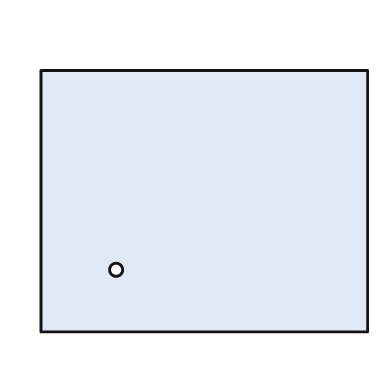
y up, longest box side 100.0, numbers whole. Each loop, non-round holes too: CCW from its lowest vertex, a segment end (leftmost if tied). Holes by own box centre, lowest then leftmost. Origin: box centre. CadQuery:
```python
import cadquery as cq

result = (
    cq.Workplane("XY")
    .moveTo(-50.0, -40.0)
    .lineTo(50.0, -40.0)
    .lineTo(50.0, 40.0)
    .lineTo(-50.0, 40.0)
    .close()
    .moveTo(-27.0, -21.0)
    .circle(2.0)
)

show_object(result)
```